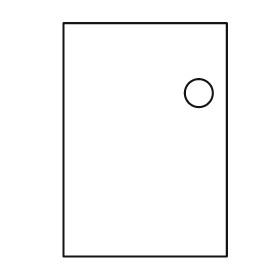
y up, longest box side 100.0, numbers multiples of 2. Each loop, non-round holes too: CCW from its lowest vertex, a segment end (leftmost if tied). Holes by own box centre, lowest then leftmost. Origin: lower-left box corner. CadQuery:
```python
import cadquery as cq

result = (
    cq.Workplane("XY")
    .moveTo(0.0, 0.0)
    .lineTo(70.0, 0.0)
    .lineTo(70.0, 100.0)
    .lineTo(0.0, 100.0)
    .close()
    .moveTo(58.0, 70.0)
    .circle(6.0)
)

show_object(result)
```